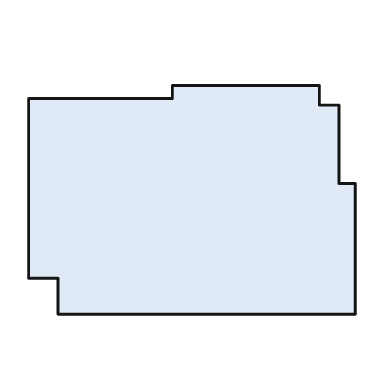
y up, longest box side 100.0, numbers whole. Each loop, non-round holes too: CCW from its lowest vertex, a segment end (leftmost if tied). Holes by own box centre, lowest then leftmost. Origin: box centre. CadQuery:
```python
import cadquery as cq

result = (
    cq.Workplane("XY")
    .moveTo(-41.0, -35.0)
    .lineTo(50.0, -35.0)
    .lineTo(50.0, 5.0)
    .lineTo(45.0, 5.0)
    .lineTo(45.0, 29.0)
    .lineTo(39.0, 29.0)
    .lineTo(39.0, 35.0)
    .lineTo(-6.0, 35.0)
    .lineTo(-6.0, 31.0)
    .lineTo(-50.0, 31.0)
    .lineTo(-50.0, -24.0)
    .lineTo(-41.0, -24.0)
    .close()
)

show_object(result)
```